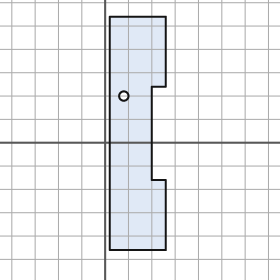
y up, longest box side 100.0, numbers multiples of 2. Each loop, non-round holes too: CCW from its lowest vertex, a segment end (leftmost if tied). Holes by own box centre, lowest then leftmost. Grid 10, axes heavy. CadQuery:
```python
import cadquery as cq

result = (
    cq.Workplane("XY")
    .moveTo(2.0, -46.0)
    .lineTo(26.0, -46.0)
    .lineTo(26.0, -16.0)
    .lineTo(20.0, -16.0)
    .lineTo(20.0, 24.0)
    .lineTo(26.0, 24.0)
    .lineTo(26.0, 54.0)
    .lineTo(2.0, 54.0)
    .close()
    .moveTo(8.0, 20.0)
    .circle(2.0)
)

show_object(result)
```